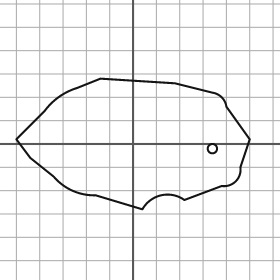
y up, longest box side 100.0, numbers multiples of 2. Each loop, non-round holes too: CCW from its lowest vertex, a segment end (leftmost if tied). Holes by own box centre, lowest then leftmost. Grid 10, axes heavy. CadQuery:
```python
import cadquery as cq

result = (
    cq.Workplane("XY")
    .moveTo(4.0, -28.0)
    .threePointArc((12.0, -22.0), (22.0, -24.0))
    .lineTo(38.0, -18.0)
    .threePointArc((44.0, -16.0), (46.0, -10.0))
    .lineTo(50.0, 2.0)
    .lineTo(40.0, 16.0)
    .threePointArc((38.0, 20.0), (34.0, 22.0))
    .lineTo(18.0, 26.0)
    .lineTo(-14.0, 28.0)
    .lineTo(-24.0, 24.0)
    .threePointArc((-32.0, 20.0), (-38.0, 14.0))
    .lineTo(-50.0, 2.0)
    .lineTo(-44.0, -6.0)
    .lineTo(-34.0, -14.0)
    .threePointArc((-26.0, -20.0), (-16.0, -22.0))
    .close()
    .moveTo(34.0, -2.0)
    .circle(2.0)
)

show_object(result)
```